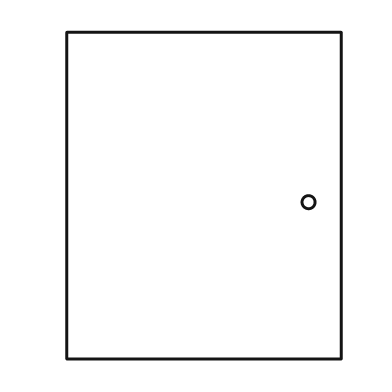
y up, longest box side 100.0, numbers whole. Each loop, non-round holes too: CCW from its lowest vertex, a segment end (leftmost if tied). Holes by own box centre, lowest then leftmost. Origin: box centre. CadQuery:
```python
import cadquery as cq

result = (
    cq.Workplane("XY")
    .moveTo(-42.0, -50.0)
    .lineTo(42.0, -50.0)
    .lineTo(42.0, 50.0)
    .lineTo(-42.0, 50.0)
    .close()
    .moveTo(32.0, -2.0)
    .circle(2.0)
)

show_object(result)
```